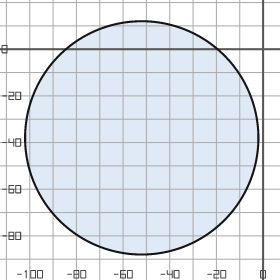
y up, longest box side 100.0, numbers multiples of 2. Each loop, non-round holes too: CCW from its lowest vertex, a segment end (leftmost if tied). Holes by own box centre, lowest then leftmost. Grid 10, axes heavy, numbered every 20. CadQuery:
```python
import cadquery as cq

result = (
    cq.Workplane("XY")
    .moveTo(-52.0, -38.0)
    .circle(50.0)
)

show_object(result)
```